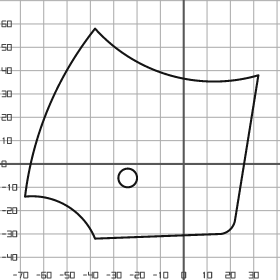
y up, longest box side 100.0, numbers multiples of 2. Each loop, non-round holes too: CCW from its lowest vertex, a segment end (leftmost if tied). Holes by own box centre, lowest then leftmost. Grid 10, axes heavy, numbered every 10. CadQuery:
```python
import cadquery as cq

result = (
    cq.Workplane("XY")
    .moveTo(-38.0, -32.0)
    .lineTo(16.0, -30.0)
    .threePointArc((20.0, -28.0), (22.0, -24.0))
    .lineTo(32.0, 38.0)
    .threePointArc((-6.0, 38.0), (-38.0, 58.0))
    .threePointArc((-58.0, 24.0), (-68.0, -14.0))
    .threePointArc((-50.0, -18.0), (-38.0, -32.0))
    .close()
    .moveTo(-24.0, -6.0)
    .circle(4.0)
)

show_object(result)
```